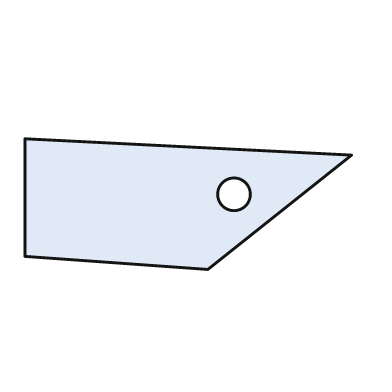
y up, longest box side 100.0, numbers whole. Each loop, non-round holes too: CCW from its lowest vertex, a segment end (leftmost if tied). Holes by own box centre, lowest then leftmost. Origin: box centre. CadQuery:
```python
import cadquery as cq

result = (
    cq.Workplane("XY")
    .moveTo(6.0, -20.0)
    .lineTo(50.0, 15.0)
    .lineTo(-50.0, 20.0)
    .lineTo(-50.0, -16.0)
    .close()
    .moveTo(14.0, 3.0)
    .circle(5.0)
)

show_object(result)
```